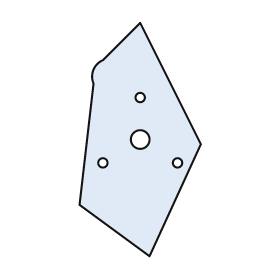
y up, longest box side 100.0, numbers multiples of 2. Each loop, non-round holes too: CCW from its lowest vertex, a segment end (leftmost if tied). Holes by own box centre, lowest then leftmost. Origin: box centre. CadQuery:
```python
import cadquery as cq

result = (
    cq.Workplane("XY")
    .moveTo(4.0, -50.0)
    .lineTo(26.0, -2.0)
    .lineTo(0.0, 50.0)
    .lineTo(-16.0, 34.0)
    .threePointArc((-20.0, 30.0), (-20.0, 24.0))
    .lineTo(-26.0, -28.0)
    .close()
    .moveTo(-16.0, -10.0)
    .circle(2.0)
    .moveTo(16.0, -10.0)
    .circle(2.0)
    .moveTo(0.0, 0.0)
    .circle(4.0)
    .moveTo(0.0, 18.0)
    .circle(2.0)
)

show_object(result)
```